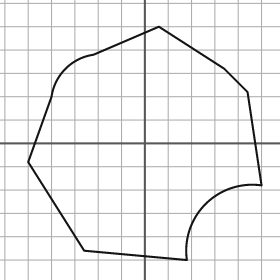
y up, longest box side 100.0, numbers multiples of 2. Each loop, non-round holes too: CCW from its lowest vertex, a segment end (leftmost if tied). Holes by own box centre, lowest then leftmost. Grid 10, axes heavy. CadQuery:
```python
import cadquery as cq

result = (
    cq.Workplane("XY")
    .moveTo(18.0, -50.0)
    .threePointArc((26.0, -26.0), (50.0, -18.0))
    .lineTo(44.0, 22.0)
    .lineTo(34.0, 32.0)
    .lineTo(6.0, 50.0)
    .lineTo(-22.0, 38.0)
    .threePointArc((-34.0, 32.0), (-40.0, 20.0))
    .lineTo(-50.0, -8.0)
    .lineTo(-26.0, -46.0)
    .close()
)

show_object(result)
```